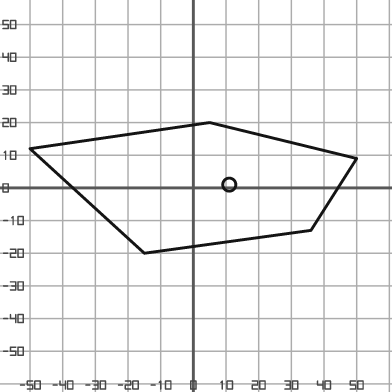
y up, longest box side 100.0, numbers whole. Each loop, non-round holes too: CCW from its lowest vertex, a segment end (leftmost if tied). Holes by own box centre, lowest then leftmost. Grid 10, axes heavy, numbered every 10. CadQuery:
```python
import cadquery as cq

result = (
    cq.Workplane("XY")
    .moveTo(-15.0, -20.0)
    .lineTo(36.0, -13.0)
    .lineTo(50.0, 9.0)
    .lineTo(5.0, 20.0)
    .lineTo(-50.0, 12.0)
    .close()
    .moveTo(11.0, 1.0)
    .circle(2.0)
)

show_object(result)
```